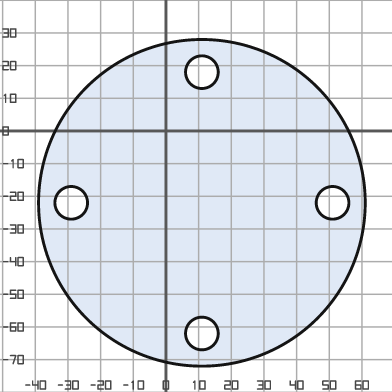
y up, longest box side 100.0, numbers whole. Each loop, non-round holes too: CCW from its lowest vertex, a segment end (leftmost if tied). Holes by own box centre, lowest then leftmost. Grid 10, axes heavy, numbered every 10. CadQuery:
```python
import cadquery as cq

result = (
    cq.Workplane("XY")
    .moveTo(11.0, -22.0)
    .circle(50.0)
    .moveTo(11.0, -62.0)
    .circle(5.0)
    .moveTo(-29.0, -22.0)
    .circle(5.0)
    .moveTo(51.0, -22.0)
    .circle(5.0)
    .moveTo(11.0, 18.0)
    .circle(5.0)
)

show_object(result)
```